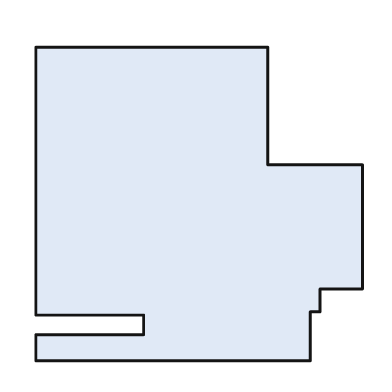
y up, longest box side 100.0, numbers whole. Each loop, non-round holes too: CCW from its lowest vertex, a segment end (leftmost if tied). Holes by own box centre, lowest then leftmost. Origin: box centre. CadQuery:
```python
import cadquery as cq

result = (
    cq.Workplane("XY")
    .moveTo(-50.0, -48.0)
    .lineTo(34.0, -48.0)
    .lineTo(34.0, -33.0)
    .lineTo(37.0, -33.0)
    .lineTo(37.0, -26.0)
    .lineTo(50.0, -26.0)
    .lineTo(50.0, 12.0)
    .lineTo(21.0, 12.0)
    .lineTo(21.0, 48.0)
    .lineTo(-50.0, 48.0)
    .lineTo(-50.0, -34.0)
    .lineTo(-17.0, -34.0)
    .lineTo(-17.0, -40.0)
    .lineTo(-50.0, -40.0)
    .close()
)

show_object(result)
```